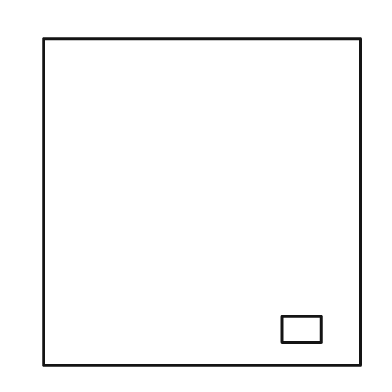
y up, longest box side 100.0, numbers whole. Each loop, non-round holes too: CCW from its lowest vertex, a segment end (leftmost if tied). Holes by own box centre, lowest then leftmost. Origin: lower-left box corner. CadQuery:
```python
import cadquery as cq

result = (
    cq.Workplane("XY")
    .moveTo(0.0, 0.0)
    .lineTo(97.0, 0.0)
    .lineTo(97.0, 100.0)
    .lineTo(0.0, 100.0)
    .close()
    .moveTo(73.0, 7.0)
    .lineTo(85.0, 7.0)
    .lineTo(85.0, 15.0)
    .lineTo(73.0, 15.0)
    .close()
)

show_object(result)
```